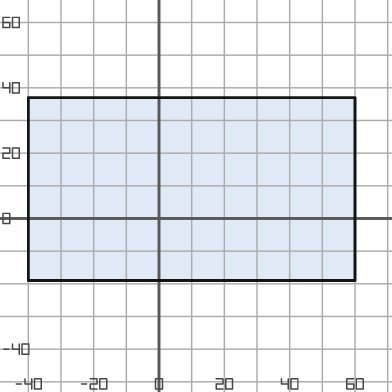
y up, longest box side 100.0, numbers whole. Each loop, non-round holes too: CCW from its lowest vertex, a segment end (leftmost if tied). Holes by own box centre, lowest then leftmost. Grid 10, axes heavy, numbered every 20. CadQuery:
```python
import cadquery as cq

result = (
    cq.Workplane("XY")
    .moveTo(-40.0, -19.0)
    .lineTo(60.0, -19.0)
    .lineTo(60.0, 37.0)
    .lineTo(-40.0, 37.0)
    .close()
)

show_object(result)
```